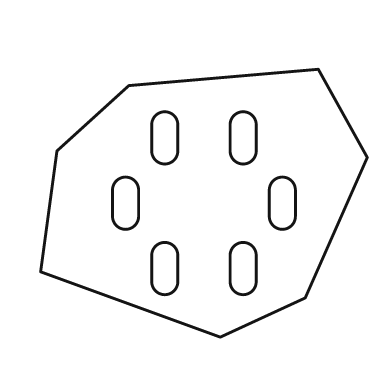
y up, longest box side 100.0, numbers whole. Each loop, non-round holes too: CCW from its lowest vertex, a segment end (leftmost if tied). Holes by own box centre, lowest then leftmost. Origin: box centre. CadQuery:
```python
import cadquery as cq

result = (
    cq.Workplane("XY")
    .moveTo(5.0, -41.0)
    .lineTo(31.0, -29.0)
    .lineTo(50.0, 14.0)
    .lineTo(35.0, 41.0)
    .lineTo(-23.0, 36.0)
    .lineTo(-45.0, 16.0)
    .lineTo(-50.0, -21.0)
    .close()
    .moveTo(-16.0, -24.0)
    .threePointArc((-12.0, -28.0), (-8.0, -24.0))
    .lineTo(-8.0, -16.0)
    .threePointArc((-12.0, -12.0), (-16.0, -16.0))
    .close()
    .moveTo(8.0, -24.0)
    .threePointArc((12.0, -28.0), (16.0, -24.0))
    .lineTo(16.0, -16.0)
    .threePointArc((12.0, -12.0), (8.0, -16.0))
    .close()
    .moveTo(-28.0, -4.0)
    .threePointArc((-24.0, -8.0), (-20.0, -4.0))
    .lineTo(-20.0, 4.0)
    .threePointArc((-24.0, 8.0), (-28.0, 4.0))
    .close()
    .moveTo(20.0, -4.0)
    .threePointArc((24.0, -8.0), (28.0, -4.0))
    .lineTo(28.0, 4.0)
    .threePointArc((24.0, 8.0), (20.0, 4.0))
    .close()
    .moveTo(-16.0, 16.0)
    .threePointArc((-12.0, 12.0), (-8.0, 16.0))
    .lineTo(-8.0, 24.0)
    .threePointArc((-12.0, 28.0), (-16.0, 24.0))
    .close()
    .moveTo(8.0, 16.0)
    .threePointArc((12.0, 12.0), (16.0, 16.0))
    .lineTo(16.0, 24.0)
    .threePointArc((12.0, 28.0), (8.0, 24.0))
    .close()
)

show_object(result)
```